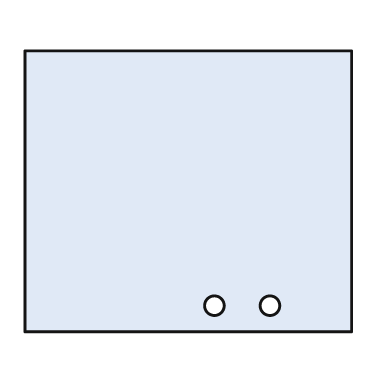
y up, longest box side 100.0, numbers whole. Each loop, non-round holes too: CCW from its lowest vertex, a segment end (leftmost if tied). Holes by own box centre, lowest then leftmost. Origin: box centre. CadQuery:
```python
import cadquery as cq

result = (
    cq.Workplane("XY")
    .moveTo(-50.0, -43.0)
    .lineTo(50.0, -43.0)
    .lineTo(50.0, 43.0)
    .lineTo(-50.0, 43.0)
    .close()
    .moveTo(8.0, -35.0)
    .circle(3.0)
    .moveTo(25.0, -35.0)
    .circle(3.0)
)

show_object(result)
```